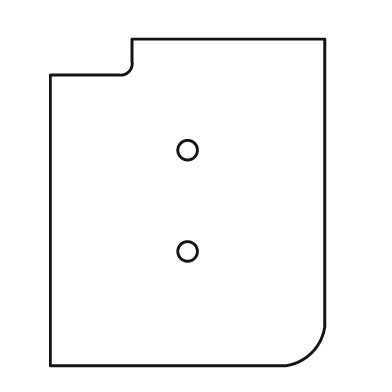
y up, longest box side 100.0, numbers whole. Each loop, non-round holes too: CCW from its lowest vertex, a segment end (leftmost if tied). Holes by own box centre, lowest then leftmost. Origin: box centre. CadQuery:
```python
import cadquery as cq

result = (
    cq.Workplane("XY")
    .moveTo(-42.0, -50.0)
    .lineTo(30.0, -50.0)
    .threePointArc((38.0, -46.0), (42.0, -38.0))
    .lineTo(42.0, 50.0)
    .lineTo(-17.0, 50.0)
    .lineTo(-17.0, 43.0)
    .threePointArc((-18.0, 40.0), (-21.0, 39.0))
    .lineTo(-42.0, 39.0)
    .close()
    .moveTo(0.0, -15.0)
    .circle(3.0)
    .moveTo(0.0, 16.0)
    .circle(3.0)
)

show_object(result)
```